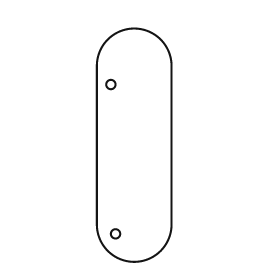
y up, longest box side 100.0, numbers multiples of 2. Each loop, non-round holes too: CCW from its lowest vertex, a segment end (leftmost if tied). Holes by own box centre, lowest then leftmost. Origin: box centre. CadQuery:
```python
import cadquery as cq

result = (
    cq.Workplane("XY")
    .moveTo(-16.0, -34.0)
    .threePointArc((0.0, -50.0), (16.0, -34.0))
    .lineTo(16.0, 34.0)
    .threePointArc((0.0, 50.0), (-16.0, 34.0))
    .close()
    .moveTo(-8.0, -38.0)
    .circle(2.0)
    .moveTo(-10.0, 26.0)
    .circle(2.0)
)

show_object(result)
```